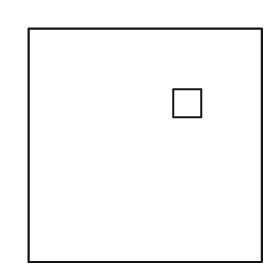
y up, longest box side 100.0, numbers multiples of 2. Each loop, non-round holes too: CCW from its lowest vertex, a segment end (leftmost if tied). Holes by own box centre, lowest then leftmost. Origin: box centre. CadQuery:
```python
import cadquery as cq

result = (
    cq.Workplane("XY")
    .moveTo(-50.0, -50.0)
    .lineTo(50.0, -50.0)
    .lineTo(50.0, 50.0)
    .lineTo(-50.0, 50.0)
    .close()
    .moveTo(12.0, 12.0)
    .lineTo(24.0, 12.0)
    .lineTo(24.0, 24.0)
    .lineTo(12.0, 24.0)
    .close()
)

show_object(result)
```